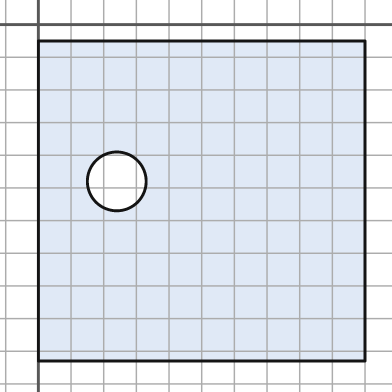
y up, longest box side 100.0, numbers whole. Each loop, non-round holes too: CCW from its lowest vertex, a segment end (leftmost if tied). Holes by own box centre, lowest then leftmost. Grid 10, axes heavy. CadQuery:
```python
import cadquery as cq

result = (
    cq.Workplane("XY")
    .moveTo(0.0, -103.0)
    .lineTo(100.0, -103.0)
    .lineTo(100.0, -5.0)
    .lineTo(0.0, -5.0)
    .close()
    .moveTo(24.0, -48.0)
    .circle(9.0)
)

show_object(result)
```